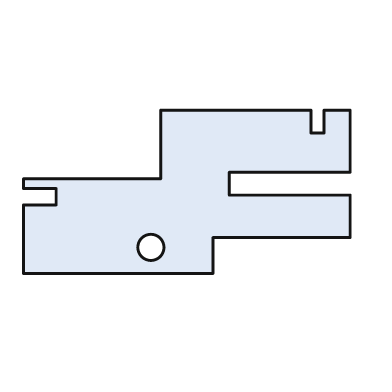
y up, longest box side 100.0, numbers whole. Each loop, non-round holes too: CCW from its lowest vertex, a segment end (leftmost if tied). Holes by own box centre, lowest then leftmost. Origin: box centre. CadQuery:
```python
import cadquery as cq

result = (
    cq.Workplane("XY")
    .moveTo(-50.0, -25.0)
    .lineTo(8.0, -25.0)
    .lineTo(8.0, -14.0)
    .lineTo(50.0, -14.0)
    .lineTo(50.0, -1.0)
    .lineTo(13.0, -1.0)
    .lineTo(13.0, 6.0)
    .lineTo(50.0, 6.0)
    .lineTo(50.0, 25.0)
    .lineTo(42.0, 25.0)
    .lineTo(42.0, 18.0)
    .lineTo(38.0, 18.0)
    .lineTo(38.0, 25.0)
    .lineTo(-8.0, 25.0)
    .lineTo(-8.0, 4.0)
    .lineTo(-50.0, 4.0)
    .lineTo(-50.0, 1.0)
    .lineTo(-40.0, 1.0)
    .lineTo(-40.0, -4.0)
    .lineTo(-50.0, -4.0)
    .close()
    .moveTo(-11.0, -17.0)
    .circle(4.0)
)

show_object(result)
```